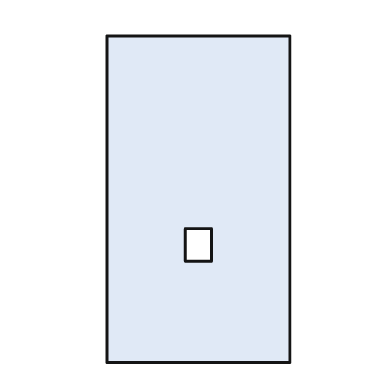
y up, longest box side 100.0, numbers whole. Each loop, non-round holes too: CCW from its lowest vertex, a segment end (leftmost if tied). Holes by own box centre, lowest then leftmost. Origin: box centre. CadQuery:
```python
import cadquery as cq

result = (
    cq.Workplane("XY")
    .moveTo(-28.0, -50.0)
    .lineTo(28.0, -50.0)
    .lineTo(28.0, 50.0)
    .lineTo(-28.0, 50.0)
    .close()
    .moveTo(-4.0, -19.0)
    .lineTo(4.0, -19.0)
    .lineTo(4.0, -9.0)
    .lineTo(-4.0, -9.0)
    .close()
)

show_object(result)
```